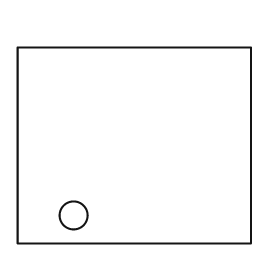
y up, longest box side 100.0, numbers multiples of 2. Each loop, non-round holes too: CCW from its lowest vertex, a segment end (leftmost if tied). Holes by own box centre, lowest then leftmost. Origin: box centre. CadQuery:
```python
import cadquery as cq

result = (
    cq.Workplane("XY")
    .moveTo(-50.0, -42.0)
    .lineTo(50.0, -42.0)
    .lineTo(50.0, 42.0)
    .lineTo(-50.0, 42.0)
    .close()
    .moveTo(-26.0, -30.0)
    .circle(6.0)
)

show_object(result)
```